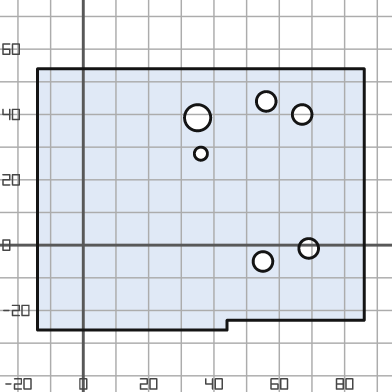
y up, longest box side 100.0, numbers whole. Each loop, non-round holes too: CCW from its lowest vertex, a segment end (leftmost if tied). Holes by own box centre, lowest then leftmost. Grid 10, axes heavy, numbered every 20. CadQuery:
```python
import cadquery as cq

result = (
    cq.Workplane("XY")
    .moveTo(-14.0, -26.0)
    .lineTo(44.0, -26.0)
    .lineTo(44.0, -23.0)
    .lineTo(86.0, -23.0)
    .lineTo(86.0, 54.0)
    .lineTo(-14.0, 54.0)
    .close()
    .moveTo(55.0, -5.0)
    .circle(3.0)
    .moveTo(69.0, -1.0)
    .circle(3.0)
    .moveTo(36.0, 28.0)
    .circle(2.0)
    .moveTo(35.0, 39.0)
    .circle(4.0)
    .moveTo(67.0, 40.0)
    .circle(3.0)
    .moveTo(56.0, 44.0)
    .circle(3.0)
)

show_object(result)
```